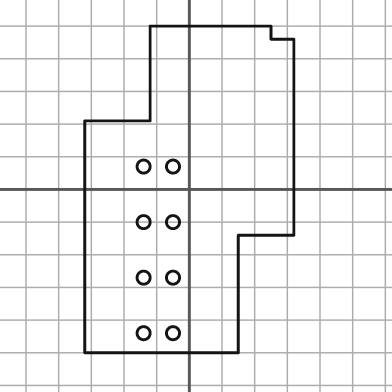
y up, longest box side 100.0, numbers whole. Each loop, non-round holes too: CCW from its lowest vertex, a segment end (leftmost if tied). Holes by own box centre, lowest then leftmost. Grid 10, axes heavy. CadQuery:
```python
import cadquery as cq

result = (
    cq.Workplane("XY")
    .moveTo(-32.0, -50.0)
    .lineTo(15.0, -50.0)
    .lineTo(15.0, -14.0)
    .lineTo(32.0, -14.0)
    .lineTo(32.0, 46.0)
    .lineTo(25.0, 46.0)
    .lineTo(25.0, 50.0)
    .lineTo(-12.0, 50.0)
    .lineTo(-12.0, 21.0)
    .lineTo(-32.0, 21.0)
    .close()
    .moveTo(-14.0, -44.0)
    .circle(2.0)
    .moveTo(-5.0, -44.0)
    .circle(2.0)
    .moveTo(-14.0, -27.0)
    .circle(2.0)
    .moveTo(-5.0, -27.0)
    .circle(2.0)
    .moveTo(-14.0, -10.0)
    .circle(2.0)
    .moveTo(-5.0, -10.0)
    .circle(2.0)
    .moveTo(-14.0, 7.0)
    .circle(2.0)
    .moveTo(-5.0, 7.0)
    .circle(2.0)
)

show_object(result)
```